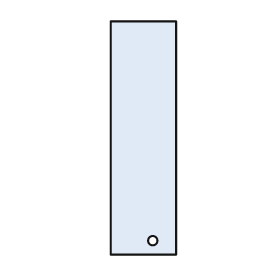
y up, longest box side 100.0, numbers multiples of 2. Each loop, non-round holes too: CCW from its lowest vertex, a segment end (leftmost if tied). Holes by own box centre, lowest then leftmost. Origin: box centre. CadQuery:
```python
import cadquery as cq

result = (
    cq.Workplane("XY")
    .moveTo(-14.0, -50.0)
    .lineTo(14.0, -50.0)
    .lineTo(14.0, 50.0)
    .lineTo(-14.0, 50.0)
    .close()
    .moveTo(4.0, -44.0)
    .circle(2.0)
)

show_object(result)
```